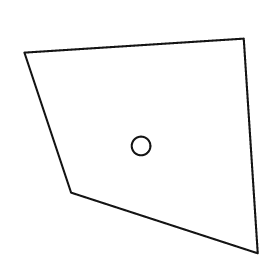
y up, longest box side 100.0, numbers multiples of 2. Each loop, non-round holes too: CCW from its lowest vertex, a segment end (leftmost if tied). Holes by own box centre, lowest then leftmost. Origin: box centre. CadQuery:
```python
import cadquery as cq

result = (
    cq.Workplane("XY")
    .moveTo(50.0, -46.0)
    .lineTo(44.0, 46.0)
    .lineTo(-50.0, 40.0)
    .lineTo(-30.0, -20.0)
    .close()
    .moveTo(0.0, 0.0)
    .circle(4.0)
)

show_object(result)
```